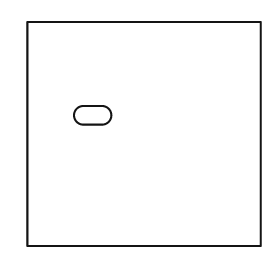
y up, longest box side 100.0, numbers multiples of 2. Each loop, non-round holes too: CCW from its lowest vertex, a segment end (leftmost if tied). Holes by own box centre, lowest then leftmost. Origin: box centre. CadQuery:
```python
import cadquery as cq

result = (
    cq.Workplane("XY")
    .moveTo(-50.0, -48.0)
    .lineTo(50.0, -48.0)
    .lineTo(50.0, 48.0)
    .lineTo(-50.0, 48.0)
    .close()
    .moveTo(-26.0, 4.0)
    .lineTo(-18.0, 4.0)
    .threePointArc((-14.0, 8.0), (-18.0, 12.0))
    .lineTo(-26.0, 12.0)
    .threePointArc((-30.0, 8.0), (-26.0, 4.0))
    .close()
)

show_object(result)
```